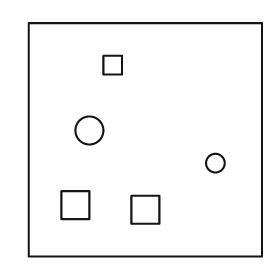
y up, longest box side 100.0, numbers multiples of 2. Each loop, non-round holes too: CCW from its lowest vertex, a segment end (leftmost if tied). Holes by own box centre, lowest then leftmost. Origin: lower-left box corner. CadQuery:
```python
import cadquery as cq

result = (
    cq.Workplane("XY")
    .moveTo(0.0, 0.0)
    .lineTo(100.0, 0.0)
    .lineTo(100.0, 100.0)
    .lineTo(0.0, 100.0)
    .close()
    .moveTo(44.0, 14.0)
    .lineTo(56.0, 14.0)
    .lineTo(56.0, 26.0)
    .lineTo(44.0, 26.0)
    .close()
    .moveTo(14.0, 16.0)
    .lineTo(26.0, 16.0)
    .lineTo(26.0, 28.0)
    .lineTo(14.0, 28.0)
    .close()
    .moveTo(80.0, 40.0)
    .circle(4.0)
    .moveTo(26.0, 54.0)
    .circle(6.0)
    .moveTo(32.0, 78.0)
    .lineTo(40.0, 78.0)
    .lineTo(40.0, 86.0)
    .lineTo(32.0, 86.0)
    .close()
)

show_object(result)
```